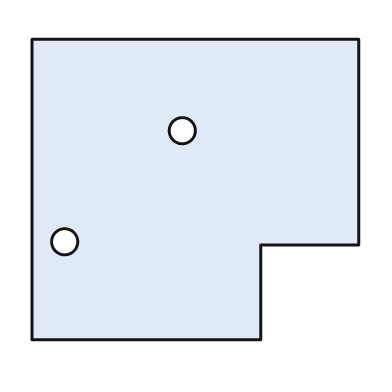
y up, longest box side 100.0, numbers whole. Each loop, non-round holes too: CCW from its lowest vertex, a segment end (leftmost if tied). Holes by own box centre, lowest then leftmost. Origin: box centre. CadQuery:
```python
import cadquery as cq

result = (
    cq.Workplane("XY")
    .moveTo(-50.0, -46.0)
    .lineTo(20.0, -46.0)
    .lineTo(20.0, -17.0)
    .lineTo(50.0, -17.0)
    .lineTo(50.0, 46.0)
    .lineTo(-50.0, 46.0)
    .close()
    .moveTo(-40.0, -16.0)
    .circle(4.0)
    .moveTo(-4.0, 18.0)
    .circle(4.0)
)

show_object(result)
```